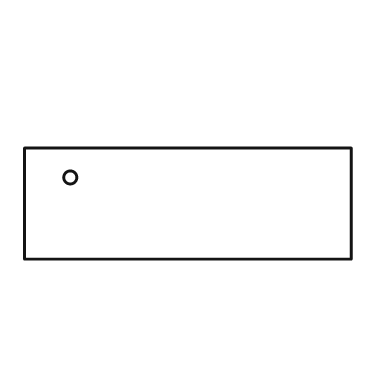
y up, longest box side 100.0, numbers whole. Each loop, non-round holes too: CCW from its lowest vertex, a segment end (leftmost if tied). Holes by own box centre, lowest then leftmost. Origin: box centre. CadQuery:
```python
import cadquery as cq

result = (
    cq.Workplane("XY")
    .moveTo(-50.0, -17.0)
    .lineTo(50.0, -17.0)
    .lineTo(50.0, 17.0)
    .lineTo(-50.0, 17.0)
    .close()
    .moveTo(-36.0, 8.0)
    .circle(2.0)
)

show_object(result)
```